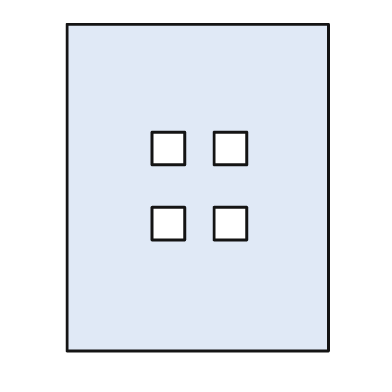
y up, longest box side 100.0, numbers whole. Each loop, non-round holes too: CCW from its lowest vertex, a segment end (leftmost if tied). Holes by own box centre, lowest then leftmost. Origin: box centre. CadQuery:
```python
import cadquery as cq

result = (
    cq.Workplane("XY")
    .moveTo(-40.0, -50.0)
    .lineTo(40.0, -50.0)
    .lineTo(40.0, 50.0)
    .lineTo(-40.0, 50.0)
    .close()
    .moveTo(-14.0, -16.0)
    .lineTo(-4.0, -16.0)
    .lineTo(-4.0, -6.0)
    .lineTo(-14.0, -6.0)
    .close()
    .moveTo(5.0, -16.0)
    .lineTo(15.0, -16.0)
    .lineTo(15.0, -6.0)
    .lineTo(5.0, -6.0)
    .close()
    .moveTo(-14.0, 7.0)
    .lineTo(-4.0, 7.0)
    .lineTo(-4.0, 17.0)
    .lineTo(-14.0, 17.0)
    .close()
    .moveTo(5.0, 7.0)
    .lineTo(15.0, 7.0)
    .lineTo(15.0, 17.0)
    .lineTo(5.0, 17.0)
    .close()
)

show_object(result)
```